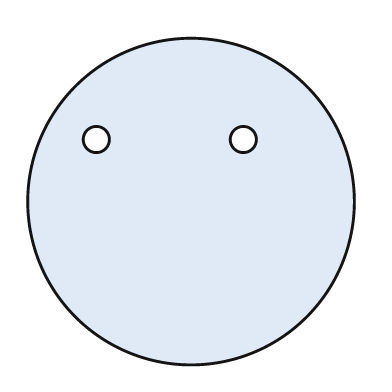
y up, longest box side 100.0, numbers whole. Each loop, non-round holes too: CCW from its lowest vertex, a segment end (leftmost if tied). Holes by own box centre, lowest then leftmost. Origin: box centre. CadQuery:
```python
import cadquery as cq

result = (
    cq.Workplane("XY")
    .moveTo(0.0, 0.0)
    .circle(50.0)
    .moveTo(-29.0, 19.0)
    .circle(4.0)
    .moveTo(16.0, 19.0)
    .circle(4.0)
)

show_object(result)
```